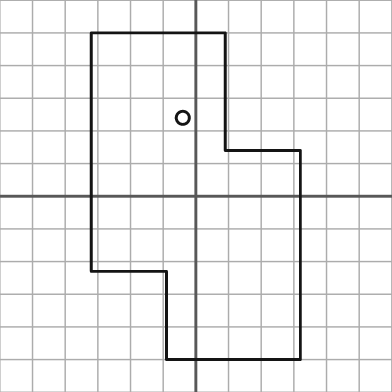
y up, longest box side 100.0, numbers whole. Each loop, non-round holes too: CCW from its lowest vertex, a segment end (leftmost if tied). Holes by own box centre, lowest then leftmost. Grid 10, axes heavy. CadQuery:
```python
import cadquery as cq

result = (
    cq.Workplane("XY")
    .moveTo(-9.0, -50.0)
    .lineTo(32.0, -50.0)
    .lineTo(32.0, 14.0)
    .lineTo(9.0, 14.0)
    .lineTo(9.0, 50.0)
    .lineTo(-32.0, 50.0)
    .lineTo(-32.0, -23.0)
    .lineTo(-9.0, -23.0)
    .close()
    .moveTo(-4.0, 24.0)
    .circle(2.0)
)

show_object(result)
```